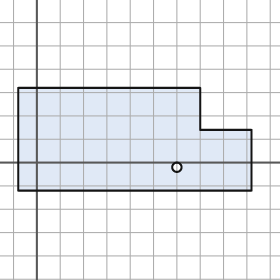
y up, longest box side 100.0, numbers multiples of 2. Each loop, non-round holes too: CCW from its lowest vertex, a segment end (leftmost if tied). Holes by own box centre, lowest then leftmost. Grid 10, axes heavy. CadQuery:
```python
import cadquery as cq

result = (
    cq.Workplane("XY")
    .moveTo(-8.0, -12.0)
    .lineTo(92.0, -12.0)
    .lineTo(92.0, 14.0)
    .lineTo(70.0, 14.0)
    .lineTo(70.0, 32.0)
    .lineTo(-8.0, 32.0)
    .close()
    .moveTo(60.0, -2.0)
    .circle(2.0)
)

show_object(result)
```